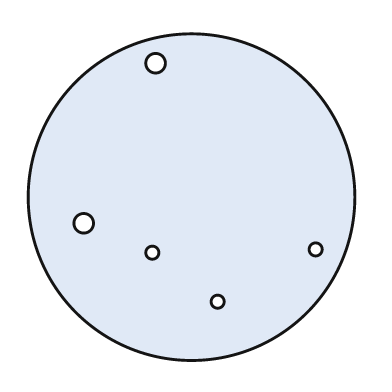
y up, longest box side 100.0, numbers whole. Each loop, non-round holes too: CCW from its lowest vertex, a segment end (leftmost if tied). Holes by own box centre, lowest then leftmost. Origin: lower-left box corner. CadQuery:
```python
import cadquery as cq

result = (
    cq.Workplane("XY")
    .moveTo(50.0, 50.0)
    .circle(50.0)
    .moveTo(58.0, 18.0)
    .circle(2.0)
    .moveTo(38.0, 33.0)
    .circle(2.0)
    .moveTo(88.0, 34.0)
    .circle(2.0)
    .moveTo(17.0, 42.0)
    .circle(3.0)
    .moveTo(39.0, 91.0)
    .circle(3.0)
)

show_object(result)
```